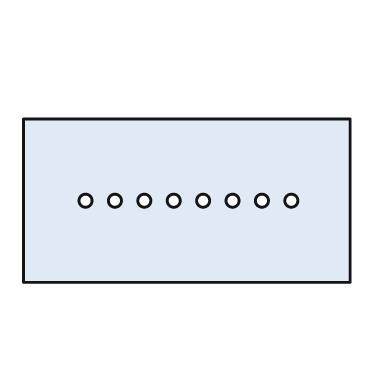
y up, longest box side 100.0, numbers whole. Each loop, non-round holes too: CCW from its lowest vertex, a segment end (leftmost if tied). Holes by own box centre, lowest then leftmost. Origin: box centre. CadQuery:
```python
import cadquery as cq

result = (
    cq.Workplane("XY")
    .moveTo(-50.0, -25.0)
    .lineTo(50.0, -25.0)
    .lineTo(50.0, 25.0)
    .lineTo(-50.0, 25.0)
    .close()
    .moveTo(-31.0, 0.0)
    .circle(2.0)
    .moveTo(-22.0, 0.0)
    .circle(2.0)
    .moveTo(-13.0, 0.0)
    .circle(2.0)
    .moveTo(-4.0, 0.0)
    .circle(2.0)
    .moveTo(5.0, 0.0)
    .circle(2.0)
    .moveTo(14.0, 0.0)
    .circle(2.0)
    .moveTo(23.0, 0.0)
    .circle(2.0)
    .moveTo(32.0, 0.0)
    .circle(2.0)
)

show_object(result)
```